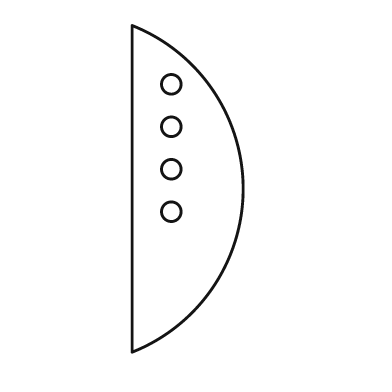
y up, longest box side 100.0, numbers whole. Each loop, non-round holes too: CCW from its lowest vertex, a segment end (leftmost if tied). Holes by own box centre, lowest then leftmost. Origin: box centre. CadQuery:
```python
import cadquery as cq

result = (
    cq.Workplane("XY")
    .moveTo(-17.0, -50.0)
    .threePointArc((17.0, 0.0), (-17.0, 50.0))
    .close()
    .moveTo(-5.0, -7.0)
    .circle(3.0)
    .moveTo(-5.0, 6.0)
    .circle(3.0)
    .moveTo(-5.0, 19.0)
    .circle(3.0)
    .moveTo(-5.0, 32.0)
    .circle(3.0)
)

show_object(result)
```